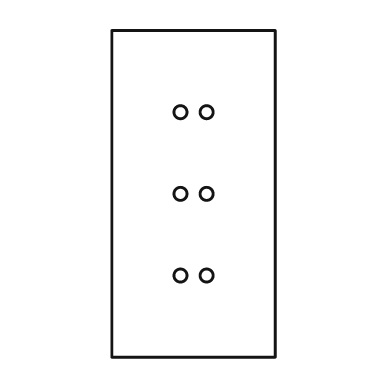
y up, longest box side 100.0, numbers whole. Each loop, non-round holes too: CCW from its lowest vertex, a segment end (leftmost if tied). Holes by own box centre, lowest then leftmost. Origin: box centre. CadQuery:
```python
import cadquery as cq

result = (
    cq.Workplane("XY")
    .moveTo(-25.0, -50.0)
    .lineTo(25.0, -50.0)
    .lineTo(25.0, 50.0)
    .lineTo(-25.0, 50.0)
    .close()
    .moveTo(-4.0, -25.0)
    .circle(2.0)
    .moveTo(4.0, -25.0)
    .circle(2.0)
    .moveTo(-4.0, 0.0)
    .circle(2.0)
    .moveTo(4.0, 0.0)
    .circle(2.0)
    .moveTo(-4.0, 25.0)
    .circle(2.0)
    .moveTo(4.0, 25.0)
    .circle(2.0)
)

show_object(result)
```